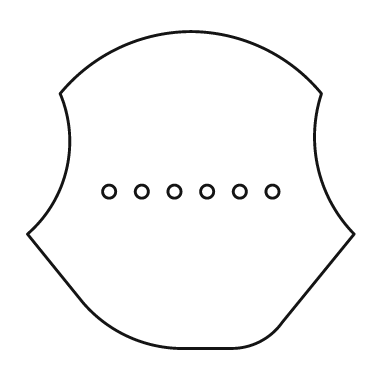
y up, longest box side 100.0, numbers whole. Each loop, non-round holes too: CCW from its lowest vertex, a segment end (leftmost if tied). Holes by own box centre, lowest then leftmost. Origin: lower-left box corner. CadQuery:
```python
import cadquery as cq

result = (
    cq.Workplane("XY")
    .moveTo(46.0, 0.0)
    .lineTo(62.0, 0.0)
    .threePointArc((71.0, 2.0), (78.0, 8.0))
    .lineTo(100.0, 35.0)
    .threePointArc((89.0, 55.0), (90.0, 78.0))
    .threePointArc((72.0, 92.0), (50.0, 97.0))
    .threePointArc((28.0, 92.0), (10.0, 78.0))
    .threePointArc((12.0, 55.0), (0.0, 35.0))
    .lineTo(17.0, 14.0)
    .threePointArc((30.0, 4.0), (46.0, 0.0))
    .close()
    .moveTo(25.0, 48.0)
    .circle(2.0)
    .moveTo(35.0, 48.0)
    .circle(2.0)
    .moveTo(45.0, 48.0)
    .circle(2.0)
    .moveTo(55.0, 48.0)
    .circle(2.0)
    .moveTo(65.0, 48.0)
    .circle(2.0)
    .moveTo(75.0, 48.0)
    .circle(2.0)
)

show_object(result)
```